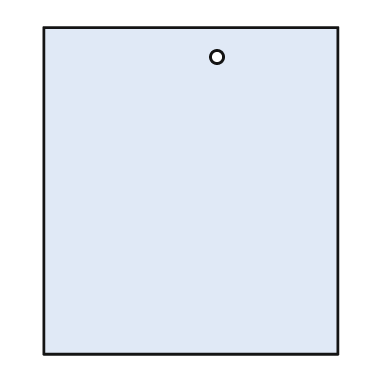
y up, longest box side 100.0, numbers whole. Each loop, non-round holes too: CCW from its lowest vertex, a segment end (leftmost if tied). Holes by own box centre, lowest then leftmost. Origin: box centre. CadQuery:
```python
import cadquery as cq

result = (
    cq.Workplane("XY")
    .moveTo(-45.0, -50.0)
    .lineTo(45.0, -50.0)
    .lineTo(45.0, 50.0)
    .lineTo(-45.0, 50.0)
    .close()
    .moveTo(8.0, 41.0)
    .circle(2.0)
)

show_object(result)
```